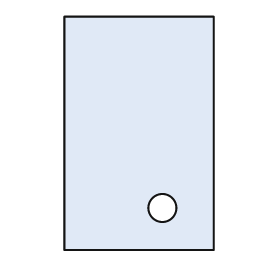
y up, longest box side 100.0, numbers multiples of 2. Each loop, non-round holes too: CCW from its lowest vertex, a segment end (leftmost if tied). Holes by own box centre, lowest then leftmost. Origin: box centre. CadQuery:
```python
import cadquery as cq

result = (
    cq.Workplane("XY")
    .moveTo(-32.0, -50.0)
    .lineTo(32.0, -50.0)
    .lineTo(32.0, 50.0)
    .lineTo(-32.0, 50.0)
    .close()
    .moveTo(10.0, -32.0)
    .circle(6.0)
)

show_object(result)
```